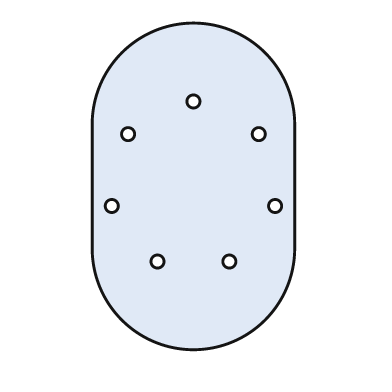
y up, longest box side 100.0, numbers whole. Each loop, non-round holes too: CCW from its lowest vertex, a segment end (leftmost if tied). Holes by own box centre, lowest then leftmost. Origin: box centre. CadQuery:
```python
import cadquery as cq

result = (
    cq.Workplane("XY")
    .moveTo(-31.0, -19.0)
    .threePointArc((0.0, -50.0), (31.0, -19.0))
    .lineTo(31.0, 19.0)
    .threePointArc((0.0, 50.0), (-31.0, 19.0))
    .close()
    .moveTo(-11.0, -23.0)
    .circle(2.0)
    .moveTo(11.0, -23.0)
    .circle(2.0)
    .moveTo(-25.0, -6.0)
    .circle(2.0)
    .moveTo(25.0, -6.0)
    .circle(2.0)
    .moveTo(-20.0, 16.0)
    .circle(2.0)
    .moveTo(20.0, 16.0)
    .circle(2.0)
    .moveTo(0.0, 26.0)
    .circle(2.0)
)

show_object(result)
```